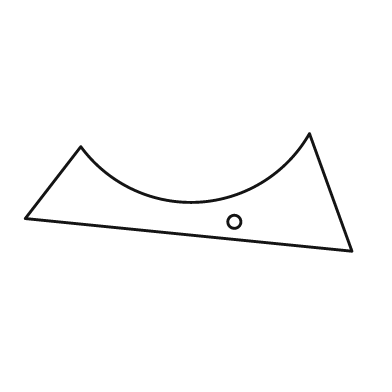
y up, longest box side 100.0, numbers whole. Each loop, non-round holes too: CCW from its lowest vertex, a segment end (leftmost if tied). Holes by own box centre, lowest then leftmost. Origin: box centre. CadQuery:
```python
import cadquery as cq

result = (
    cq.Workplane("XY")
    .moveTo(50.0, -18.0)
    .lineTo(37.0, 18.0)
    .threePointArc((3.0, -3.0), (-33.0, 14.0))
    .lineTo(-50.0, -8.0)
    .close()
    .moveTo(14.0, -9.0)
    .circle(2.0)
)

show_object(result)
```